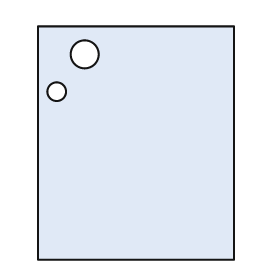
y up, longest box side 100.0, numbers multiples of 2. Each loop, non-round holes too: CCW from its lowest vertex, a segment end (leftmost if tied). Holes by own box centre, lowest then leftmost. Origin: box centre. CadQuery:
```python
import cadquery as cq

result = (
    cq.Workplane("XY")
    .moveTo(-42.0, -50.0)
    .lineTo(42.0, -50.0)
    .lineTo(42.0, 50.0)
    .lineTo(-42.0, 50.0)
    .close()
    .moveTo(-34.0, 22.0)
    .circle(4.0)
    .moveTo(-22.0, 38.0)
    .circle(6.0)
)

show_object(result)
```